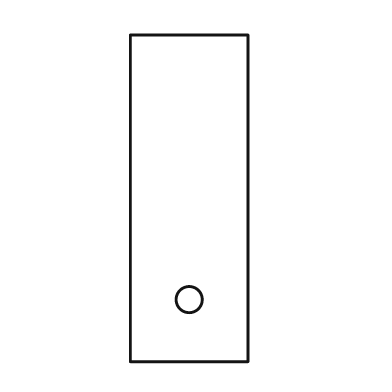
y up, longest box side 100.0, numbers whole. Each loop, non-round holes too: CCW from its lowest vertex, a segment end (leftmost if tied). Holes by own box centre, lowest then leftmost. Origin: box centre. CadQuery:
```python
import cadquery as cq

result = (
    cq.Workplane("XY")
    .moveTo(-18.0, -50.0)
    .lineTo(18.0, -50.0)
    .lineTo(18.0, 50.0)
    .lineTo(-18.0, 50.0)
    .close()
    .moveTo(0.0, -31.0)
    .circle(4.0)
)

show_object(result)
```